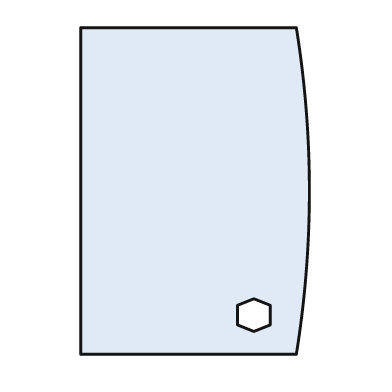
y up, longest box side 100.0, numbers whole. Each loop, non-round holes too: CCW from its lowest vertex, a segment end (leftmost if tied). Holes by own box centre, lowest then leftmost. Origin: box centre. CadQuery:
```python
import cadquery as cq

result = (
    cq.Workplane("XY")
    .moveTo(-35.0, -50.0)
    .lineTo(31.0, -50.0)
    .threePointArc((35.0, 0.0), (31.0, 50.0))
    .lineTo(-35.0, 50.0)
    .close()
    .moveTo(18.0, -43.0)
    .lineTo(23.0, -41.0)
    .lineTo(23.0, -35.0)
    .lineTo(18.0, -33.0)
    .lineTo(13.0, -35.0)
    .lineTo(13.0, -41.0)
    .close()
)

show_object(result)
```